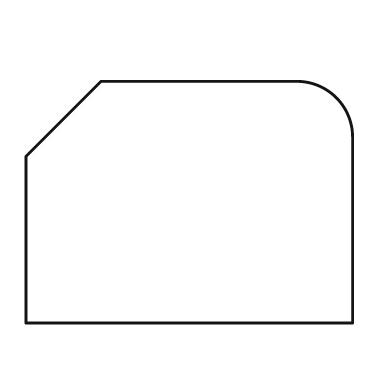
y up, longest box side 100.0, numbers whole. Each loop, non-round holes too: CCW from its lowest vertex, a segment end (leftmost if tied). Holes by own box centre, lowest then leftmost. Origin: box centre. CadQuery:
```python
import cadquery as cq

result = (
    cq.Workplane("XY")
    .moveTo(-50.0, -37.0)
    .lineTo(50.0, -37.0)
    .lineTo(50.0, 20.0)
    .threePointArc((45.0, 32.0), (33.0, 37.0))
    .lineTo(-27.0, 37.0)
    .lineTo(-50.0, 14.0)
    .close()
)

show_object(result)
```